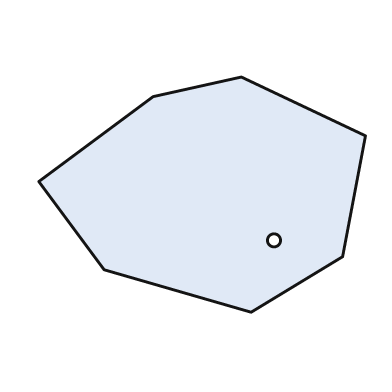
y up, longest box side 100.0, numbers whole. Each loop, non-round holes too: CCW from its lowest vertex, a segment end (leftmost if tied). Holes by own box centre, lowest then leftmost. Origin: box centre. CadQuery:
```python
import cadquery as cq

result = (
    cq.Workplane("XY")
    .moveTo(15.0, -36.0)
    .lineTo(43.0, -19.0)
    .lineTo(50.0, 18.0)
    .lineTo(12.0, 36.0)
    .lineTo(-15.0, 30.0)
    .lineTo(-50.0, 4.0)
    .lineTo(-30.0, -23.0)
    .close()
    .moveTo(22.0, -14.0)
    .circle(2.0)
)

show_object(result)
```